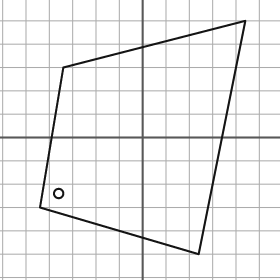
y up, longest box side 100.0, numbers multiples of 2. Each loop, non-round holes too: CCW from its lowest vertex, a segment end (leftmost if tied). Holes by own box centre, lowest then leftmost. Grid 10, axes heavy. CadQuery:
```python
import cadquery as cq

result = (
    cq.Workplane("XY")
    .moveTo(24.0, -50.0)
    .lineTo(44.0, 50.0)
    .lineTo(-34.0, 30.0)
    .lineTo(-44.0, -30.0)
    .close()
    .moveTo(-36.0, -24.0)
    .circle(2.0)
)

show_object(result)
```